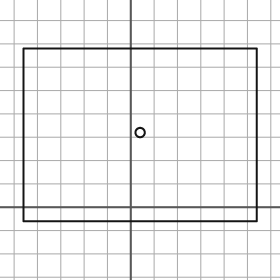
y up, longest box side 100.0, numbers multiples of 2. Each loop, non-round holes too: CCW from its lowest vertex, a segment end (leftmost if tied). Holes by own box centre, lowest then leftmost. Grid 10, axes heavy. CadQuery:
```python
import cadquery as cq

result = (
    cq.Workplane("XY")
    .moveTo(-46.0, -6.0)
    .lineTo(54.0, -6.0)
    .lineTo(54.0, 68.0)
    .lineTo(-46.0, 68.0)
    .close()
    .moveTo(4.0, 32.0)
    .circle(2.0)
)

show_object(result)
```